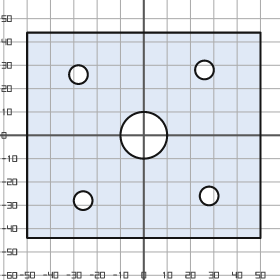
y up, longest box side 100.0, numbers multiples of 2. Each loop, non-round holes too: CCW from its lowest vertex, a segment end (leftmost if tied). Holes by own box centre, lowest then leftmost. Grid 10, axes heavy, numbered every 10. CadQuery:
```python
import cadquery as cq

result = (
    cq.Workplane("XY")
    .moveTo(-50.0, -44.0)
    .lineTo(50.0, -44.0)
    .lineTo(50.0, 44.0)
    .lineTo(-50.0, 44.0)
    .close()
    .moveTo(-26.0, -28.0)
    .circle(4.0)
    .moveTo(28.0, -26.0)
    .circle(4.0)
    .moveTo(0.0, 0.0)
    .circle(10.0)
    .moveTo(-28.0, 26.0)
    .circle(4.0)
    .moveTo(26.0, 28.0)
    .circle(4.0)
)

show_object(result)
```